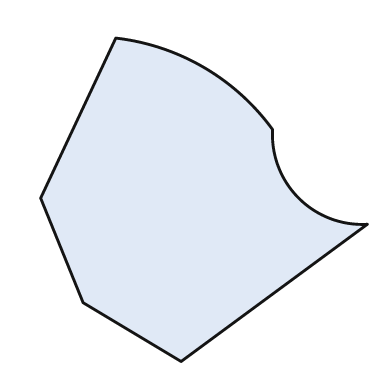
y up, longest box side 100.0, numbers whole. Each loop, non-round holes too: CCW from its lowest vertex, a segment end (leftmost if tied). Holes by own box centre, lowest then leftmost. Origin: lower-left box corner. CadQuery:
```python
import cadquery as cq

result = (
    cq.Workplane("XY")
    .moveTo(43.0, 0.0)
    .lineTo(100.0, 42.0)
    .threePointArc((79.0, 50.0), (71.0, 71.0))
    .threePointArc((50.0, 90.0), (23.0, 99.0))
    .lineTo(0.0, 50.0)
    .lineTo(13.0, 18.0)
    .close()
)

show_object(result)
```